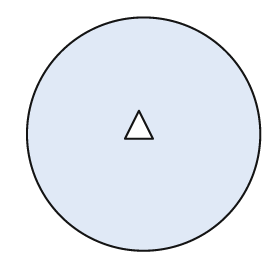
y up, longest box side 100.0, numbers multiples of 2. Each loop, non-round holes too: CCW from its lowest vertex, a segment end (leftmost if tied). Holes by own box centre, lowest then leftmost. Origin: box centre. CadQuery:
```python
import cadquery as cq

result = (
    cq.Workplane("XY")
    .moveTo(0.0, 0.0)
    .circle(50.0)
    .moveTo(-8.0, -2.0)
    .lineTo(4.0, -2.0)
    .lineTo(-2.0, 10.0)
    .close()
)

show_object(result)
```